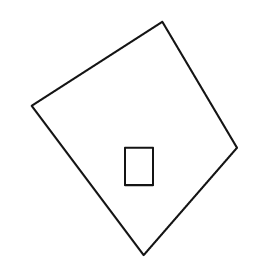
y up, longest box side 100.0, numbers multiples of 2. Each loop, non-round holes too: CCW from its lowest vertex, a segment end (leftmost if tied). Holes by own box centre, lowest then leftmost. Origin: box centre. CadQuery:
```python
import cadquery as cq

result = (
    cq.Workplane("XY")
    .moveTo(4.0, -50.0)
    .lineTo(44.0, -4.0)
    .lineTo(12.0, 50.0)
    .lineTo(-44.0, 14.0)
    .close()
    .moveTo(-4.0, -20.0)
    .lineTo(8.0, -20.0)
    .lineTo(8.0, -4.0)
    .lineTo(-4.0, -4.0)
    .close()
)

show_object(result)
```